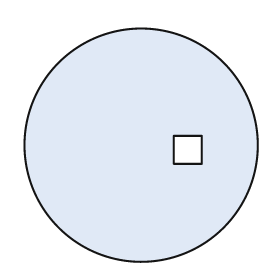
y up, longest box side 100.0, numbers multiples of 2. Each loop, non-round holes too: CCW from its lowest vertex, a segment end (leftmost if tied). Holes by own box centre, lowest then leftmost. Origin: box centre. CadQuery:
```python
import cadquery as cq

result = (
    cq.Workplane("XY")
    .moveTo(0.0, 0.0)
    .circle(50.0)
    .moveTo(14.0, -8.0)
    .lineTo(26.0, -8.0)
    .lineTo(26.0, 4.0)
    .lineTo(14.0, 4.0)
    .close()
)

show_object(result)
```